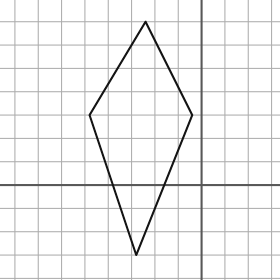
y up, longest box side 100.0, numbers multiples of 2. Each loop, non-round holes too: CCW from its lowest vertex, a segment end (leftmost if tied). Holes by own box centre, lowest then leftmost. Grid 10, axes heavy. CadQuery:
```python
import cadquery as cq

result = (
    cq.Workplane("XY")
    .moveTo(-28.0, -30.0)
    .lineTo(-4.0, 30.0)
    .lineTo(-24.0, 70.0)
    .lineTo(-48.0, 30.0)
    .close()
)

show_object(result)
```